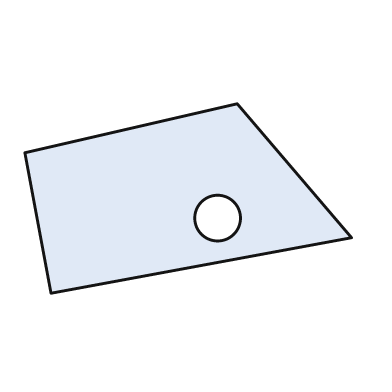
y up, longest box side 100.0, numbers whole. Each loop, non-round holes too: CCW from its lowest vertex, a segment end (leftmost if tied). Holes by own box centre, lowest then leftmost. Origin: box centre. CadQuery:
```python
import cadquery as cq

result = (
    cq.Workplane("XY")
    .moveTo(-42.0, -29.0)
    .lineTo(50.0, -12.0)
    .lineTo(15.0, 29.0)
    .lineTo(-50.0, 14.0)
    .close()
    .moveTo(9.0, -6.0)
    .circle(7.0)
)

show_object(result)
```